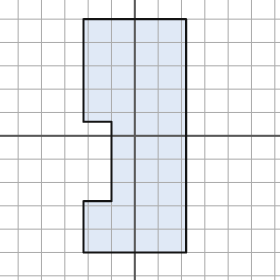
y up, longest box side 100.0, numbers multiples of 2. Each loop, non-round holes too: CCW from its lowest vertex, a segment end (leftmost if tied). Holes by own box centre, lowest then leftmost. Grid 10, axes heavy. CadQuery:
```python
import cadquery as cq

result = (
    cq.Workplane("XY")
    .moveTo(-22.0, -50.0)
    .lineTo(22.0, -50.0)
    .lineTo(22.0, 50.0)
    .lineTo(-22.0, 50.0)
    .lineTo(-22.0, 6.0)
    .lineTo(-10.0, 6.0)
    .lineTo(-10.0, -28.0)
    .lineTo(-22.0, -28.0)
    .close()
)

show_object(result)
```